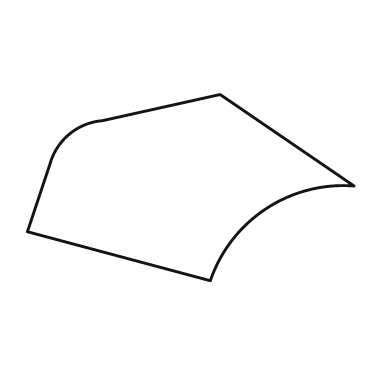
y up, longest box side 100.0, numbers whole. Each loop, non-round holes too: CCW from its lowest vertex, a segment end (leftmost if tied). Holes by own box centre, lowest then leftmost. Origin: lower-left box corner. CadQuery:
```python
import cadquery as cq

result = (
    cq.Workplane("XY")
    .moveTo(56.0, 0.0)
    .threePointArc((73.0, 22.0), (100.0, 29.0))
    .lineTo(59.0, 57.0)
    .lineTo(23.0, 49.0)
    .threePointArc((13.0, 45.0), (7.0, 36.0))
    .lineTo(0.0, 15.0)
    .close()
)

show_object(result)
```